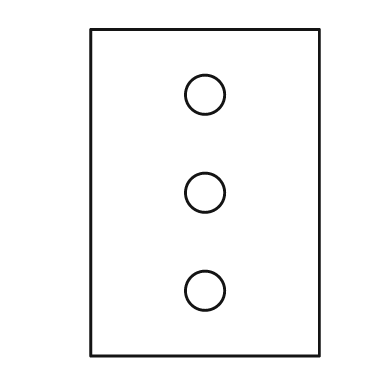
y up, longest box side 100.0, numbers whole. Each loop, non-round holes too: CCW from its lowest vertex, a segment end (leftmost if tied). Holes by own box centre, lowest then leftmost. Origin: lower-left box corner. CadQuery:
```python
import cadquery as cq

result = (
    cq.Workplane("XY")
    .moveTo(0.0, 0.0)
    .lineTo(70.0, 0.0)
    .lineTo(70.0, 100.0)
    .lineTo(0.0, 100.0)
    .close()
    .moveTo(35.0, 20.0)
    .circle(6.0)
    .moveTo(35.0, 50.0)
    .circle(6.0)
    .moveTo(35.0, 80.0)
    .circle(6.0)
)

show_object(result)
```